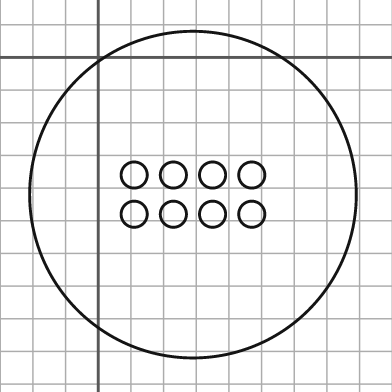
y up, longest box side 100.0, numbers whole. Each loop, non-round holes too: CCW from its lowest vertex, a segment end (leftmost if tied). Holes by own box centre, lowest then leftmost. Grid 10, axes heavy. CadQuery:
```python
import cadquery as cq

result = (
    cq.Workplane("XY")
    .moveTo(29.0, -42.0)
    .circle(50.0)
    .moveTo(11.0, -48.0)
    .circle(4.0)
    .moveTo(23.0, -48.0)
    .circle(4.0)
    .moveTo(35.0, -48.0)
    .circle(4.0)
    .moveTo(47.0, -48.0)
    .circle(4.0)
    .moveTo(11.0, -36.0)
    .circle(4.0)
    .moveTo(23.0, -36.0)
    .circle(4.0)
    .moveTo(35.0, -36.0)
    .circle(4.0)
    .moveTo(47.0, -36.0)
    .circle(4.0)
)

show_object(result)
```